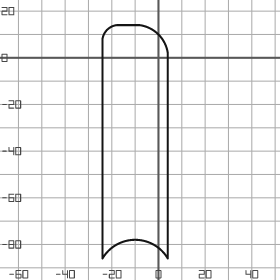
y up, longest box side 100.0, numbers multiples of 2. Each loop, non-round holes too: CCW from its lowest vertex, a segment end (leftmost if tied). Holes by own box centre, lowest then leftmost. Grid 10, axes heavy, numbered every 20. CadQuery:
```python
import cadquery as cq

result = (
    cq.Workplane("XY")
    .moveTo(-24.0, -86.0)
    .threePointArc((-10.0, -78.0), (4.0, -86.0))
    .lineTo(4.0, 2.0)
    .threePointArc((0.0, 10.0), (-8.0, 14.0))
    .lineTo(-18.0, 14.0)
    .threePointArc((-22.0, 12.0), (-24.0, 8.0))
    .close()
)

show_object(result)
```